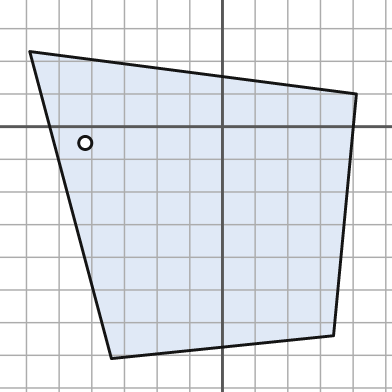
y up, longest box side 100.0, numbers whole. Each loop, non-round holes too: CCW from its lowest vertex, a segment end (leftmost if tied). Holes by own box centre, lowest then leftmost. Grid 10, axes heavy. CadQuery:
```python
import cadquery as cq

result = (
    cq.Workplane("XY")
    .moveTo(-34.0, -71.0)
    .lineTo(34.0, -64.0)
    .lineTo(41.0, 10.0)
    .lineTo(-59.0, 23.0)
    .close()
    .moveTo(-42.0, -5.0)
    .circle(2.0)
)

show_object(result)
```